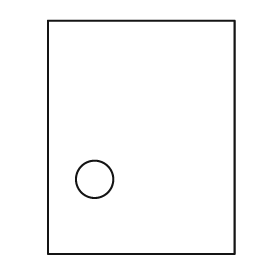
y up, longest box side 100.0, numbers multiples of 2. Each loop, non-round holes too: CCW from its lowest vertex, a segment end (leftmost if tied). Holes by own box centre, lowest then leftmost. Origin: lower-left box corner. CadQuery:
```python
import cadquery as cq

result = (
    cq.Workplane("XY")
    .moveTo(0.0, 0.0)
    .lineTo(80.0, 0.0)
    .lineTo(80.0, 100.0)
    .lineTo(0.0, 100.0)
    .close()
    .moveTo(20.0, 32.0)
    .circle(8.0)
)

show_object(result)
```